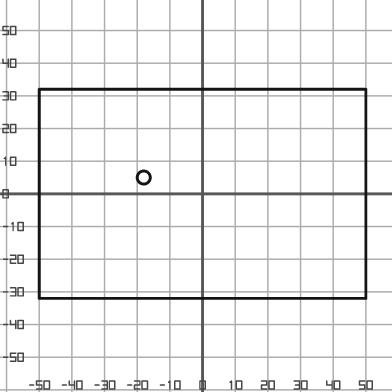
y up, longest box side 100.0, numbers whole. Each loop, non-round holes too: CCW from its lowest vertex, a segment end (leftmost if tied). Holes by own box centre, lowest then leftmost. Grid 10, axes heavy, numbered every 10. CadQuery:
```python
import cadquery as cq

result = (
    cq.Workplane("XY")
    .moveTo(-50.0, -32.0)
    .lineTo(50.0, -32.0)
    .lineTo(50.0, 32.0)
    .lineTo(-50.0, 32.0)
    .close()
    .moveTo(-18.0, 5.0)
    .circle(2.0)
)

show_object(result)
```